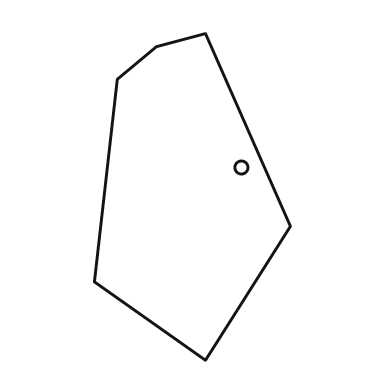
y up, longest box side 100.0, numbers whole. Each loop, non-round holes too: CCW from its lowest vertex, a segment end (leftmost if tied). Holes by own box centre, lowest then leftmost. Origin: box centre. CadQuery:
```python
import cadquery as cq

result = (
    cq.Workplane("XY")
    .moveTo(4.0, -50.0)
    .lineTo(30.0, -9.0)
    .lineTo(4.0, 50.0)
    .lineTo(-11.0, 46.0)
    .lineTo(-23.0, 36.0)
    .lineTo(-30.0, -26.0)
    .close()
    .moveTo(15.0, 9.0)
    .circle(2.0)
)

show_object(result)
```